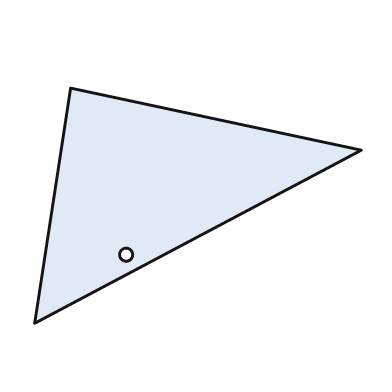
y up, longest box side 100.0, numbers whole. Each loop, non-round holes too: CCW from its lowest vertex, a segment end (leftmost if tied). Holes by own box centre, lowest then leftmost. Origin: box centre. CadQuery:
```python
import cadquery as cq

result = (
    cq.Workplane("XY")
    .moveTo(-50.0, -36.0)
    .lineTo(50.0, 17.0)
    .lineTo(-39.0, 36.0)
    .close()
    .moveTo(-22.0, -15.0)
    .circle(2.0)
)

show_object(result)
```